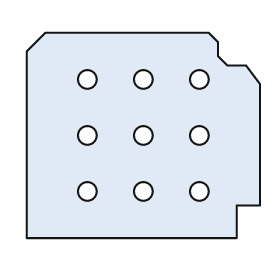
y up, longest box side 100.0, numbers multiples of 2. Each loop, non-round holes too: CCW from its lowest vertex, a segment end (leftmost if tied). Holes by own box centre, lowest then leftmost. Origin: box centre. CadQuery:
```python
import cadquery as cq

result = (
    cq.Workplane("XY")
    .moveTo(-50.0, -44.0)
    .lineTo(40.0, -44.0)
    .lineTo(40.0, -30.0)
    .lineTo(50.0, -30.0)
    .lineTo(50.0, 22.0)
    .lineTo(44.0, 30.0)
    .lineTo(36.0, 30.0)
    .lineTo(32.0, 34.0)
    .lineTo(32.0, 40.0)
    .lineTo(28.0, 44.0)
    .lineTo(-42.0, 44.0)
    .lineTo(-50.0, 36.0)
    .close()
    .moveTo(-24.0, -24.0)
    .circle(4.0)
    .moveTo(0.0, -24.0)
    .circle(4.0)
    .moveTo(24.0, -24.0)
    .circle(4.0)
    .moveTo(-24.0, 0.0)
    .circle(4.0)
    .moveTo(0.0, 0.0)
    .circle(4.0)
    .moveTo(24.0, 0.0)
    .circle(4.0)
    .moveTo(-24.0, 24.0)
    .circle(4.0)
    .moveTo(0.0, 24.0)
    .circle(4.0)
    .moveTo(24.0, 24.0)
    .circle(4.0)
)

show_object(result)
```